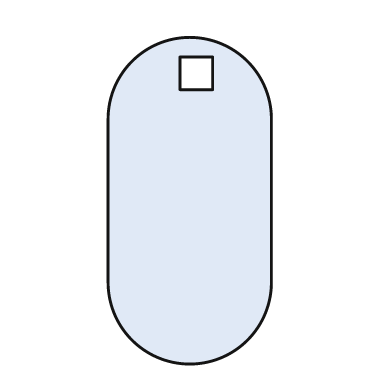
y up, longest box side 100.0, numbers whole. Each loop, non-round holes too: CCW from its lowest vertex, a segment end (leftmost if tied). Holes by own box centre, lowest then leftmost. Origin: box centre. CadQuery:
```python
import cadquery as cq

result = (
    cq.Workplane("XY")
    .moveTo(-25.0, -25.0)
    .threePointArc((0.0, -50.0), (25.0, -25.0))
    .lineTo(25.0, 25.0)
    .threePointArc((0.0, 50.0), (-25.0, 25.0))
    .close()
    .moveTo(-3.0, 34.0)
    .lineTo(7.0, 34.0)
    .lineTo(7.0, 44.0)
    .lineTo(-3.0, 44.0)
    .close()
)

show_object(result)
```